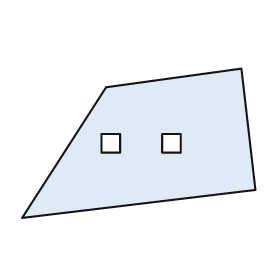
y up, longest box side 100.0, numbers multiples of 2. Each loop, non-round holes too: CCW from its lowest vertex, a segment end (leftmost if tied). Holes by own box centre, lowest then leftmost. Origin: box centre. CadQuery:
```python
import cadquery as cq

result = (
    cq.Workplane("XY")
    .moveTo(-50.0, -32.0)
    .lineTo(50.0, -20.0)
    .lineTo(44.0, 32.0)
    .lineTo(-14.0, 24.0)
    .close()
    .moveTo(-16.0, -4.0)
    .lineTo(-8.0, -4.0)
    .lineTo(-8.0, 4.0)
    .lineTo(-16.0, 4.0)
    .close()
    .moveTo(10.0, -4.0)
    .lineTo(18.0, -4.0)
    .lineTo(18.0, 4.0)
    .lineTo(10.0, 4.0)
    .close()
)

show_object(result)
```